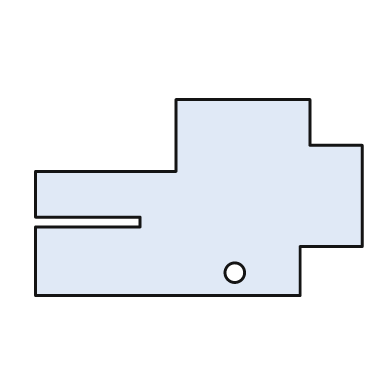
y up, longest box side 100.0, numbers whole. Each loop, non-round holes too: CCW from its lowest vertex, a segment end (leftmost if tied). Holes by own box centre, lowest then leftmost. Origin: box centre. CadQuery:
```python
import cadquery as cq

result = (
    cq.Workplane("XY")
    .moveTo(-50.0, -30.0)
    .lineTo(31.0, -30.0)
    .lineTo(31.0, -15.0)
    .lineTo(50.0, -15.0)
    .lineTo(50.0, 16.0)
    .lineTo(34.0, 16.0)
    .lineTo(34.0, 30.0)
    .lineTo(-7.0, 30.0)
    .lineTo(-7.0, 8.0)
    .lineTo(-50.0, 8.0)
    .lineTo(-50.0, -6.0)
    .lineTo(-18.0, -6.0)
    .lineTo(-18.0, -9.0)
    .lineTo(-50.0, -9.0)
    .close()
    .moveTo(11.0, -23.0)
    .circle(3.0)
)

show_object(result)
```